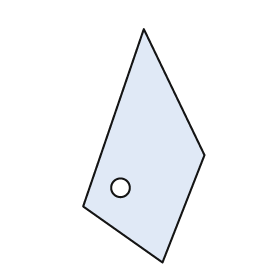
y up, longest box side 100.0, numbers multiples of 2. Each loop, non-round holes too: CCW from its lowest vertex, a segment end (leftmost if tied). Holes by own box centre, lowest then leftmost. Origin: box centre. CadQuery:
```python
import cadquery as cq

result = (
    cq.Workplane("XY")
    .moveTo(8.0, -50.0)
    .lineTo(26.0, -4.0)
    .lineTo(0.0, 50.0)
    .lineTo(-26.0, -26.0)
    .close()
    .moveTo(-10.0, -18.0)
    .circle(4.0)
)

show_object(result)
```